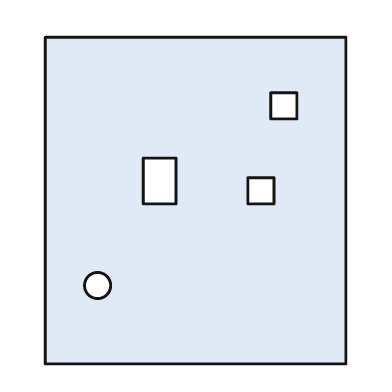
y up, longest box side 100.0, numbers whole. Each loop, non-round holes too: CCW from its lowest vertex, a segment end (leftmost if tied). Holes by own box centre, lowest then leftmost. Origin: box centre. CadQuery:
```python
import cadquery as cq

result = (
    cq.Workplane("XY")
    .moveTo(-46.0, -50.0)
    .lineTo(46.0, -50.0)
    .lineTo(46.0, 50.0)
    .lineTo(-46.0, 50.0)
    .close()
    .moveTo(-30.0, -26.0)
    .circle(4.0)
    .moveTo(16.0, -1.0)
    .lineTo(24.0, -1.0)
    .lineTo(24.0, 7.0)
    .lineTo(16.0, 7.0)
    .close()
    .moveTo(-16.0, -1.0)
    .lineTo(-6.0, -1.0)
    .lineTo(-6.0, 13.0)
    .lineTo(-16.0, 13.0)
    .close()
    .moveTo(23.0, 25.0)
    .lineTo(31.0, 25.0)
    .lineTo(31.0, 33.0)
    .lineTo(23.0, 33.0)
    .close()
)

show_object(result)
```